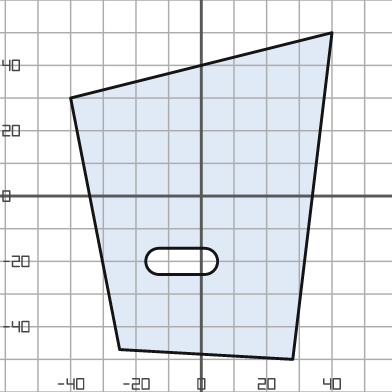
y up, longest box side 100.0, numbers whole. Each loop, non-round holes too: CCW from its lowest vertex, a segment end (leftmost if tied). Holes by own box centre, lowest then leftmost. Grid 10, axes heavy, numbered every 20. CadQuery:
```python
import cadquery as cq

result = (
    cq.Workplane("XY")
    .moveTo(28.0, -50.0)
    .lineTo(40.0, 50.0)
    .lineTo(-40.0, 30.0)
    .lineTo(-25.0, -47.0)
    .close()
    .moveTo(-13.0, -24.0)
    .lineTo(1.0, -24.0)
    .threePointArc((5.0, -20.0), (1.0, -16.0))
    .lineTo(-13.0, -16.0)
    .threePointArc((-17.0, -20.0), (-13.0, -24.0))
    .close()
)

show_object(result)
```